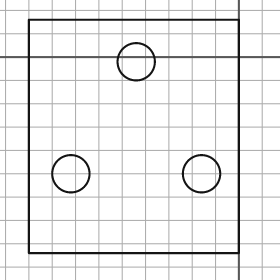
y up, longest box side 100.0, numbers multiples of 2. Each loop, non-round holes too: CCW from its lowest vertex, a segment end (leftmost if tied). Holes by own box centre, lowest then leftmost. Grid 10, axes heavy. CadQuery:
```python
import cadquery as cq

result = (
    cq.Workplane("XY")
    .moveTo(-90.0, -84.0)
    .lineTo(0.0, -84.0)
    .lineTo(0.0, 16.0)
    .lineTo(-90.0, 16.0)
    .close()
    .moveTo(-72.0, -50.0)
    .circle(8.0)
    .moveTo(-16.0, -50.0)
    .circle(8.0)
    .moveTo(-44.0, -2.0)
    .circle(8.0)
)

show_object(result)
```